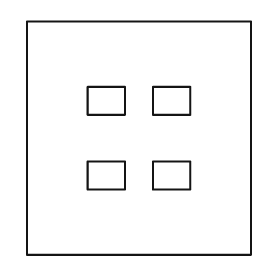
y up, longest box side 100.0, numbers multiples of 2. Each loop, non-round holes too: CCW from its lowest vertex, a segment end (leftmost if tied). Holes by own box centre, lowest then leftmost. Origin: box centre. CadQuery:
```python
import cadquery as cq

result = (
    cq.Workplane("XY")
    .moveTo(-48.0, -50.0)
    .lineTo(48.0, -50.0)
    .lineTo(48.0, 50.0)
    .lineTo(-48.0, 50.0)
    .close()
    .moveTo(-22.0, -22.0)
    .lineTo(-6.0, -22.0)
    .lineTo(-6.0, -10.0)
    .lineTo(-22.0, -10.0)
    .close()
    .moveTo(6.0, -22.0)
    .lineTo(22.0, -22.0)
    .lineTo(22.0, -10.0)
    .lineTo(6.0, -10.0)
    .close()
    .moveTo(-22.0, 10.0)
    .lineTo(-6.0, 10.0)
    .lineTo(-6.0, 22.0)
    .lineTo(-22.0, 22.0)
    .close()
    .moveTo(6.0, 10.0)
    .lineTo(22.0, 10.0)
    .lineTo(22.0, 22.0)
    .lineTo(6.0, 22.0)
    .close()
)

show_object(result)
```